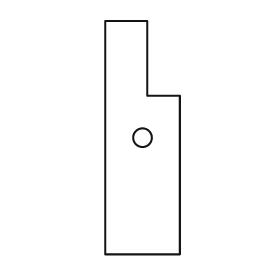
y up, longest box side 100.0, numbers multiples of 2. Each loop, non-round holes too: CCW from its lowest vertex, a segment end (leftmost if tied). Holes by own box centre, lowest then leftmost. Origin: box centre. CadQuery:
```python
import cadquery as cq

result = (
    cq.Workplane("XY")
    .moveTo(-16.0, -50.0)
    .lineTo(16.0, -50.0)
    .lineTo(16.0, 18.0)
    .lineTo(2.0, 18.0)
    .lineTo(2.0, 50.0)
    .lineTo(-16.0, 50.0)
    .close()
    .moveTo(0.0, 0.0)
    .circle(4.0)
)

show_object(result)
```